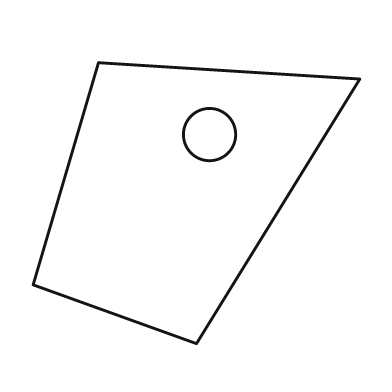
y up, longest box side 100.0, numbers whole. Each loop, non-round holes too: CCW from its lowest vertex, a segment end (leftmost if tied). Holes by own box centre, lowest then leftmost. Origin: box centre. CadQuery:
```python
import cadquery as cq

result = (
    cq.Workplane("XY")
    .moveTo(0.0, -43.0)
    .lineTo(50.0, 38.0)
    .lineTo(-30.0, 43.0)
    .lineTo(-50.0, -25.0)
    .close()
    .moveTo(4.0, 21.0)
    .circle(8.0)
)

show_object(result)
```